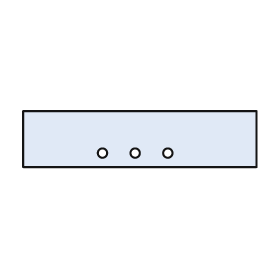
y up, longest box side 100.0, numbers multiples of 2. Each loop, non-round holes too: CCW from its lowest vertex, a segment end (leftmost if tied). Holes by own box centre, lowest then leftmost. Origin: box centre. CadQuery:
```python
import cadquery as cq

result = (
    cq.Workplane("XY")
    .moveTo(-50.0, -12.0)
    .lineTo(50.0, -12.0)
    .lineTo(50.0, 12.0)
    .lineTo(-50.0, 12.0)
    .close()
    .moveTo(-16.0, -6.0)
    .circle(2.0)
    .moveTo(-2.0, -6.0)
    .circle(2.0)
    .moveTo(12.0, -6.0)
    .circle(2.0)
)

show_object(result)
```